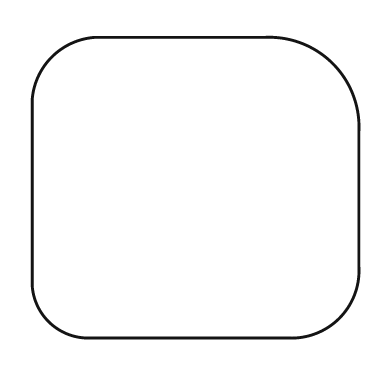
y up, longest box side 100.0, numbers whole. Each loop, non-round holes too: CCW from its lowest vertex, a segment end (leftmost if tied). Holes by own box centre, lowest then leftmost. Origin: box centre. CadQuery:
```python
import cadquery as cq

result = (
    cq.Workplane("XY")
    .moveTo(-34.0, -46.0)
    .lineTo(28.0, -46.0)
    .threePointArc((44.0, -40.0), (50.0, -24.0))
    .lineTo(50.0, 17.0)
    .threePointArc((42.0, 38.0), (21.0, 46.0))
    .lineTo(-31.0, 46.0)
    .threePointArc((-44.0, 40.0), (-50.0, 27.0))
    .lineTo(-50.0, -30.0)
    .threePointArc((-45.0, -41.0), (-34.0, -46.0))
    .close()
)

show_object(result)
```